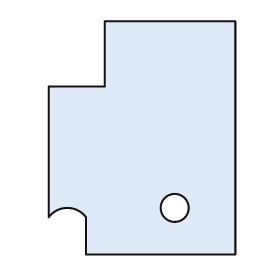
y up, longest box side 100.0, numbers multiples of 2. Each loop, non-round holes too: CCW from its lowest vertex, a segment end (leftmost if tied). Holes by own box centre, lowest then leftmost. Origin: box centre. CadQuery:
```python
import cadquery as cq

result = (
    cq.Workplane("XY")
    .moveTo(-24.0, -50.0)
    .lineTo(40.0, -50.0)
    .lineTo(40.0, 50.0)
    .lineTo(-16.0, 50.0)
    .lineTo(-16.0, 22.0)
    .lineTo(-40.0, 22.0)
    .lineTo(-40.0, -34.0)
    .threePointArc((-32.0, -30.0), (-24.0, -34.0))
    .close()
    .moveTo(14.0, -30.0)
    .circle(6.0)
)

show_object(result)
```